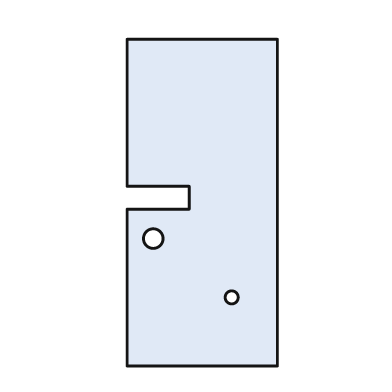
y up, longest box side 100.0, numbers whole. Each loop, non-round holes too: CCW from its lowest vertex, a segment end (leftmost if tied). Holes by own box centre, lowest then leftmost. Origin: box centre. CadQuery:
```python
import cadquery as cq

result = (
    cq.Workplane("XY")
    .moveTo(-23.0, -50.0)
    .lineTo(23.0, -50.0)
    .lineTo(23.0, 50.0)
    .lineTo(-23.0, 50.0)
    .lineTo(-23.0, 5.0)
    .lineTo(-4.0, 5.0)
    .lineTo(-4.0, -2.0)
    .lineTo(-23.0, -2.0)
    .close()
    .moveTo(9.0, -29.0)
    .circle(2.0)
    .moveTo(-15.0, -11.0)
    .circle(3.0)
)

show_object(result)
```